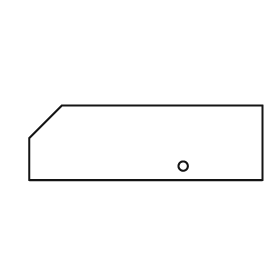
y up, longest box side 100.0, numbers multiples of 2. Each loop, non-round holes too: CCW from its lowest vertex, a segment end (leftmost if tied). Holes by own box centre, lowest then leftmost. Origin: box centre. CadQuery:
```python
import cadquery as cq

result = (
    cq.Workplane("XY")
    .moveTo(-50.0, -16.0)
    .lineTo(50.0, -16.0)
    .lineTo(50.0, 16.0)
    .lineTo(-36.0, 16.0)
    .lineTo(-50.0, 2.0)
    .close()
    .moveTo(16.0, -10.0)
    .circle(2.0)
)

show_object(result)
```